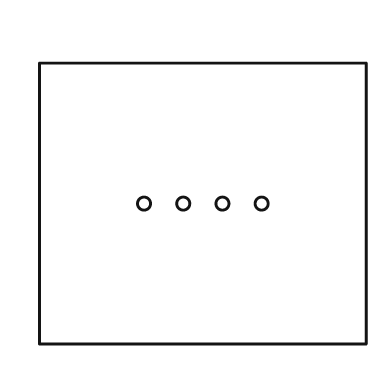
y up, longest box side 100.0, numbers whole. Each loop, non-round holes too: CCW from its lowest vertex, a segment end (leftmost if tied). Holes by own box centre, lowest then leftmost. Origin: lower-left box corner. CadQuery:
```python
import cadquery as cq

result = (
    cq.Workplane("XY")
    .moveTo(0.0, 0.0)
    .lineTo(100.0, 0.0)
    .lineTo(100.0, 86.0)
    .lineTo(0.0, 86.0)
    .close()
    .moveTo(32.0, 43.0)
    .circle(2.0)
    .moveTo(44.0, 43.0)
    .circle(2.0)
    .moveTo(56.0, 43.0)
    .circle(2.0)
    .moveTo(68.0, 43.0)
    .circle(2.0)
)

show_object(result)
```